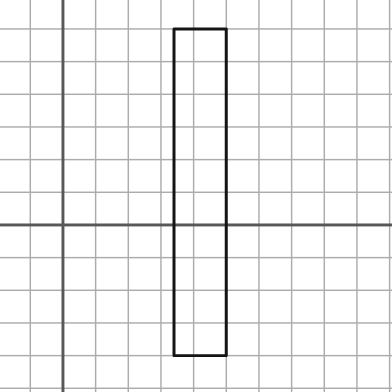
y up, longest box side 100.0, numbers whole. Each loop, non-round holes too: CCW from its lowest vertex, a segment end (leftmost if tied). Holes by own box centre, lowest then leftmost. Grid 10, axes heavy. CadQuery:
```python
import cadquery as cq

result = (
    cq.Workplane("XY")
    .moveTo(34.0, -40.0)
    .lineTo(50.0, -40.0)
    .lineTo(50.0, 60.0)
    .lineTo(34.0, 60.0)
    .close()
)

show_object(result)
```